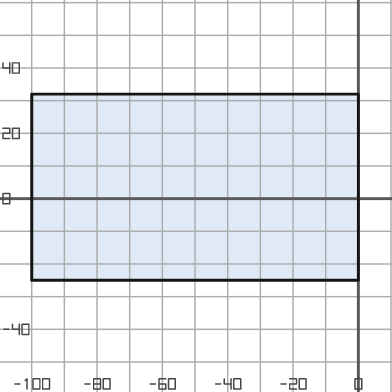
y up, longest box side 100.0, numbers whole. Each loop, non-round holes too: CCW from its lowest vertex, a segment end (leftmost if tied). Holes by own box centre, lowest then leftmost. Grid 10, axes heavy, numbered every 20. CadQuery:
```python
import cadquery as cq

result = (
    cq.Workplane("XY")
    .moveTo(-100.0, -25.0)
    .lineTo(0.0, -25.0)
    .lineTo(0.0, 32.0)
    .lineTo(-100.0, 32.0)
    .close()
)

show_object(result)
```